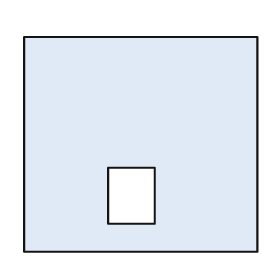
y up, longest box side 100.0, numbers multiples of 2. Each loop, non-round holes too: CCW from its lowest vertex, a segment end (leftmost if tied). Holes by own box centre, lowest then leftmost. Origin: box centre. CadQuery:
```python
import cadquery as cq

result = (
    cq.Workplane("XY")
    .moveTo(-50.0, -46.0)
    .lineTo(50.0, -46.0)
    .lineTo(50.0, 46.0)
    .lineTo(-50.0, 46.0)
    .close()
    .moveTo(-14.0, -34.0)
    .lineTo(6.0, -34.0)
    .lineTo(6.0, -10.0)
    .lineTo(-14.0, -10.0)
    .close()
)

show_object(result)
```